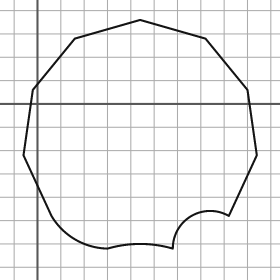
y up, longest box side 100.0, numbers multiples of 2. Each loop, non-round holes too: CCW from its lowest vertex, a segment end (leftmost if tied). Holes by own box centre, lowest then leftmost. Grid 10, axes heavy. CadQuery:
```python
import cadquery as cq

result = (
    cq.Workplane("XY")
    .moveTo(30.0, -62.0)
    .threePointArc((44.0, -60.0), (58.0, -62.0))
    .threePointArc((66.0, -48.0), (82.0, -48.0))
    .lineTo(94.0, -22.0)
    .lineTo(90.0, 6.0)
    .lineTo(72.0, 28.0)
    .lineTo(44.0, 36.0)
    .lineTo(16.0, 28.0)
    .lineTo(-2.0, 6.0)
    .lineTo(-6.0, -22.0)
    .lineTo(6.0, -48.0)
    .threePointArc((16.0, -58.0), (30.0, -62.0))
    .close()
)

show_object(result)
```